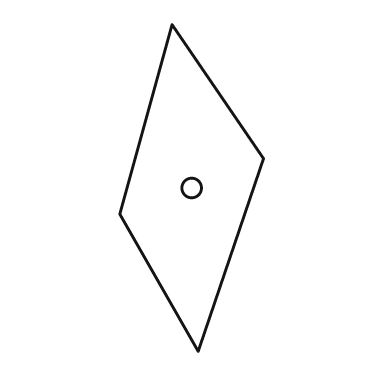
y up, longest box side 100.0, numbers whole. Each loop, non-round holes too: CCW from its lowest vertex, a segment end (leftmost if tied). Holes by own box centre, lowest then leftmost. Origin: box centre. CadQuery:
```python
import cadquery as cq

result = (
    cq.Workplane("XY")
    .moveTo(2.0, -50.0)
    .lineTo(22.0, 9.0)
    .lineTo(-6.0, 50.0)
    .lineTo(-22.0, -8.0)
    .close()
    .moveTo(0.0, 0.0)
    .circle(3.0)
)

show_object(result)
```